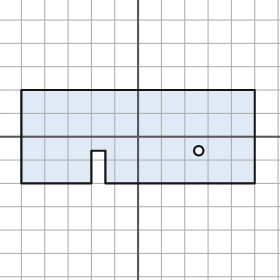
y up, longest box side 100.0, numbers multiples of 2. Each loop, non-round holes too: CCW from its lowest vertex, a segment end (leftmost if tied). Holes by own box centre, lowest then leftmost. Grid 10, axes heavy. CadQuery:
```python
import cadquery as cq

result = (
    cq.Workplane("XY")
    .moveTo(-50.0, -20.0)
    .lineTo(-20.0, -20.0)
    .lineTo(-20.0, -6.0)
    .lineTo(-14.0, -6.0)
    .lineTo(-14.0, -20.0)
    .lineTo(50.0, -20.0)
    .lineTo(50.0, 20.0)
    .lineTo(-50.0, 20.0)
    .close()
    .moveTo(26.0, -6.0)
    .circle(2.0)
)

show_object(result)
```